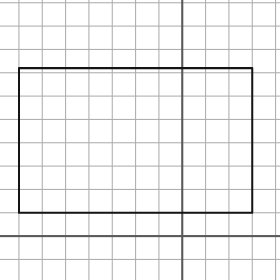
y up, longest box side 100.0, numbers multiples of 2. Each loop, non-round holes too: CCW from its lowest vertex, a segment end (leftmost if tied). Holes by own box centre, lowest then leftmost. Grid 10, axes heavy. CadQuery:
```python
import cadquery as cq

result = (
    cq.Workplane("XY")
    .moveTo(-70.0, 10.0)
    .lineTo(30.0, 10.0)
    .lineTo(30.0, 72.0)
    .lineTo(-70.0, 72.0)
    .close()
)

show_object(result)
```